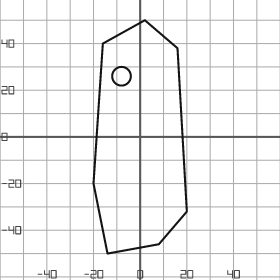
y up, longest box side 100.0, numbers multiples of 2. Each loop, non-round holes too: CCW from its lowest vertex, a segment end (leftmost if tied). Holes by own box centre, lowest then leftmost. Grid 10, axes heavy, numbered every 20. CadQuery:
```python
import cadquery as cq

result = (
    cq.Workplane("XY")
    .moveTo(-14.0, -50.0)
    .lineTo(8.0, -46.0)
    .lineTo(20.0, -32.0)
    .lineTo(16.0, 38.0)
    .lineTo(2.0, 50.0)
    .lineTo(-16.0, 40.0)
    .lineTo(-20.0, -20.0)
    .close()
    .moveTo(-8.0, 26.0)
    .circle(4.0)
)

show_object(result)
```